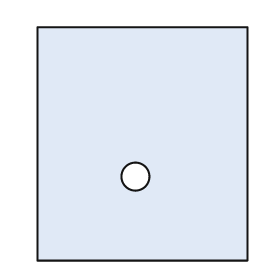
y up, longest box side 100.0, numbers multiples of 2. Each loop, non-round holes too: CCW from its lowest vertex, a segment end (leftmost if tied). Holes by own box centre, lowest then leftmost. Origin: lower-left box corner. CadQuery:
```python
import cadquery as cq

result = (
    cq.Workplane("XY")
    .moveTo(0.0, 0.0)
    .lineTo(90.0, 0.0)
    .lineTo(90.0, 100.0)
    .lineTo(0.0, 100.0)
    .close()
    .moveTo(42.0, 36.0)
    .circle(6.0)
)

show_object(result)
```